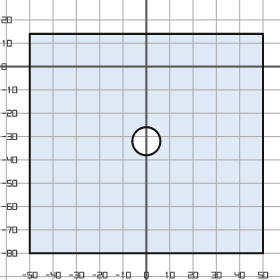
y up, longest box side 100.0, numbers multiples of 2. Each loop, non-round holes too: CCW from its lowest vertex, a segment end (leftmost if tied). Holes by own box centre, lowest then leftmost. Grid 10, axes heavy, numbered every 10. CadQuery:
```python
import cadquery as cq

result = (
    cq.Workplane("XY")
    .moveTo(-50.0, -80.0)
    .lineTo(50.0, -80.0)
    .lineTo(50.0, 14.0)
    .lineTo(-50.0, 14.0)
    .close()
    .moveTo(0.0, -32.0)
    .circle(6.0)
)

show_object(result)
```